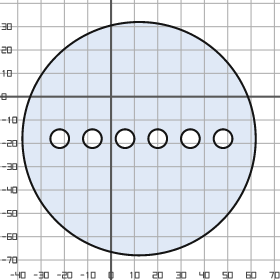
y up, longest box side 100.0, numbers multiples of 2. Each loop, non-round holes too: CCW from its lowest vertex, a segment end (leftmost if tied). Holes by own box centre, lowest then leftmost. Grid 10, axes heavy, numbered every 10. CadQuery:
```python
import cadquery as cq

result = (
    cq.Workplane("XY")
    .moveTo(12.0, -18.0)
    .circle(50.0)
    .moveTo(-22.0, -18.0)
    .circle(4.0)
    .moveTo(-8.0, -18.0)
    .circle(4.0)
    .moveTo(6.0, -18.0)
    .circle(4.0)
    .moveTo(20.0, -18.0)
    .circle(4.0)
    .moveTo(34.0, -18.0)
    .circle(4.0)
    .moveTo(48.0, -18.0)
    .circle(4.0)
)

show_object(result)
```